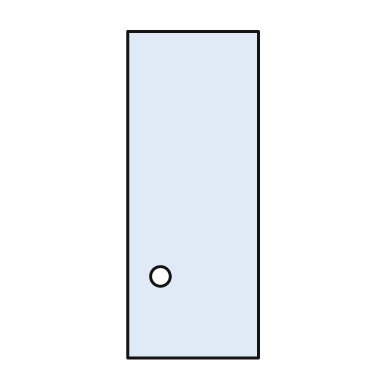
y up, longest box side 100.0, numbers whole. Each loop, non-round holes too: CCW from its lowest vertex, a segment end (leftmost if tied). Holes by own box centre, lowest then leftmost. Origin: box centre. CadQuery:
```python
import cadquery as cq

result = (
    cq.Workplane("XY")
    .moveTo(-20.0, -50.0)
    .lineTo(20.0, -50.0)
    .lineTo(20.0, 50.0)
    .lineTo(-20.0, 50.0)
    .close()
    .moveTo(-10.0, -25.0)
    .circle(3.0)
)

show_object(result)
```